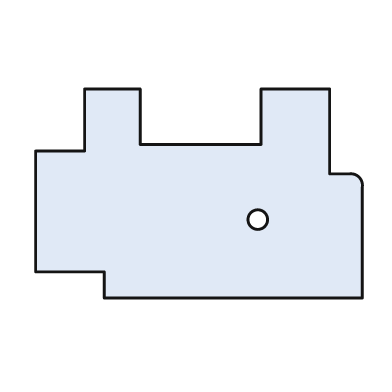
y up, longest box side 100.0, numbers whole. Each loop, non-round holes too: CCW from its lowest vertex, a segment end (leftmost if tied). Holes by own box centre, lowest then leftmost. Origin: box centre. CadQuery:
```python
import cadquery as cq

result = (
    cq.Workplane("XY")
    .moveTo(-29.0, -32.0)
    .lineTo(50.0, -32.0)
    .lineTo(50.0, 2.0)
    .threePointArc((49.0, 5.0), (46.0, 6.0))
    .lineTo(40.0, 6.0)
    .lineTo(40.0, 32.0)
    .lineTo(19.0, 32.0)
    .lineTo(19.0, 15.0)
    .lineTo(-18.0, 15.0)
    .lineTo(-18.0, 32.0)
    .lineTo(-35.0, 32.0)
    .lineTo(-35.0, 13.0)
    .lineTo(-50.0, 13.0)
    .lineTo(-50.0, -24.0)
    .lineTo(-29.0, -24.0)
    .close()
    .moveTo(18.0, -8.0)
    .circle(3.0)
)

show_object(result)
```